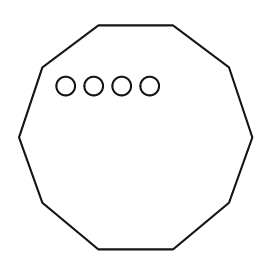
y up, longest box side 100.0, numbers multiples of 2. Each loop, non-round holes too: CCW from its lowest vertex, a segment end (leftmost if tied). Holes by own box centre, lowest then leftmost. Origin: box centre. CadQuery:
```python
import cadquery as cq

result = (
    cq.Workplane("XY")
    .moveTo(-16.0, -48.0)
    .lineTo(16.0, -48.0)
    .lineTo(40.0, -28.0)
    .lineTo(50.0, 0.0)
    .lineTo(40.0, 30.0)
    .lineTo(16.0, 48.0)
    .lineTo(-16.0, 48.0)
    .lineTo(-40.0, 30.0)
    .lineTo(-50.0, 0.0)
    .lineTo(-40.0, -28.0)
    .close()
    .moveTo(-30.0, 22.0)
    .circle(4.0)
    .moveTo(-18.0, 22.0)
    .circle(4.0)
    .moveTo(-6.0, 22.0)
    .circle(4.0)
    .moveTo(6.0, 22.0)
    .circle(4.0)
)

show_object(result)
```